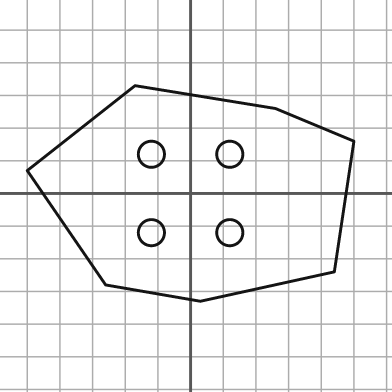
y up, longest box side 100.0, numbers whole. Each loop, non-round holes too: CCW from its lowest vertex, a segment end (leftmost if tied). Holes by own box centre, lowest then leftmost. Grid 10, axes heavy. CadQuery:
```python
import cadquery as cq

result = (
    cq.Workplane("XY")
    .moveTo(3.0, -33.0)
    .lineTo(44.0, -24.0)
    .lineTo(50.0, 16.0)
    .lineTo(26.0, 26.0)
    .lineTo(-17.0, 33.0)
    .lineTo(-50.0, 7.0)
    .lineTo(-26.0, -28.0)
    .close()
    .moveTo(-12.0, -12.0)
    .circle(4.0)
    .moveTo(12.0, -12.0)
    .circle(4.0)
    .moveTo(-12.0, 12.0)
    .circle(4.0)
    .moveTo(12.0, 12.0)
    .circle(4.0)
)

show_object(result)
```